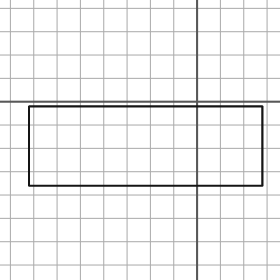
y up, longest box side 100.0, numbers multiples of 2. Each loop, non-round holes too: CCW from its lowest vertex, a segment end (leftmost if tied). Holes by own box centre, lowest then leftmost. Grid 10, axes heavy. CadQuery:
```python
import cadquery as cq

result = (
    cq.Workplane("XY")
    .moveTo(-72.0, -36.0)
    .lineTo(28.0, -36.0)
    .lineTo(28.0, -2.0)
    .lineTo(-72.0, -2.0)
    .close()
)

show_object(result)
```